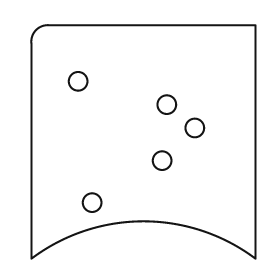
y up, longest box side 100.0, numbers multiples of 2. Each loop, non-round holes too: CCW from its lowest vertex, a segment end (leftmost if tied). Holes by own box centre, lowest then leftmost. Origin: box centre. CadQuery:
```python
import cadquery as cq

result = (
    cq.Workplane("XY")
    .moveTo(-48.0, -50.0)
    .threePointArc((0.0, -34.0), (48.0, -50.0))
    .lineTo(48.0, 50.0)
    .lineTo(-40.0, 50.0)
    .threePointArc((-46.0, 48.0), (-48.0, 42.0))
    .close()
    .moveTo(-22.0, -26.0)
    .circle(4.0)
    .moveTo(8.0, -8.0)
    .circle(4.0)
    .moveTo(22.0, 6.0)
    .circle(4.0)
    .moveTo(10.0, 16.0)
    .circle(4.0)
    .moveTo(-28.0, 26.0)
    .circle(4.0)
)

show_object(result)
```